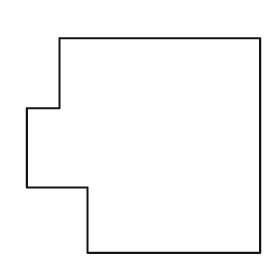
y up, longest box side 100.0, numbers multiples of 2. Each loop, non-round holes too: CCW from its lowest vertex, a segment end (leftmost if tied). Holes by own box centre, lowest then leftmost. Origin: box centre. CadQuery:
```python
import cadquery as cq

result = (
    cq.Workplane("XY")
    .moveTo(-24.0, -46.0)
    .lineTo(50.0, -46.0)
    .lineTo(50.0, 46.0)
    .lineTo(-36.0, 46.0)
    .lineTo(-36.0, 16.0)
    .lineTo(-50.0, 16.0)
    .lineTo(-50.0, -18.0)
    .lineTo(-24.0, -18.0)
    .close()
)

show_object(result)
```